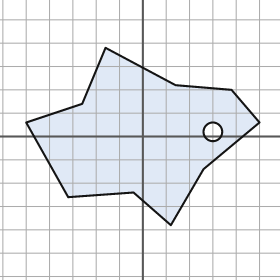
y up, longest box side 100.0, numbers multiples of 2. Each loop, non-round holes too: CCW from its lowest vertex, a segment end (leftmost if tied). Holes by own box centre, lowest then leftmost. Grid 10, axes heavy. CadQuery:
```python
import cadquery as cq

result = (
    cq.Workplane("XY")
    .moveTo(12.0, -38.0)
    .lineTo(26.0, -14.0)
    .lineTo(50.0, 6.0)
    .lineTo(38.0, 20.0)
    .lineTo(14.0, 22.0)
    .lineTo(-16.0, 38.0)
    .lineTo(-26.0, 14.0)
    .lineTo(-50.0, 6.0)
    .lineTo(-32.0, -26.0)
    .lineTo(-4.0, -24.0)
    .close()
    .moveTo(30.0, 2.0)
    .circle(4.0)
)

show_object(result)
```